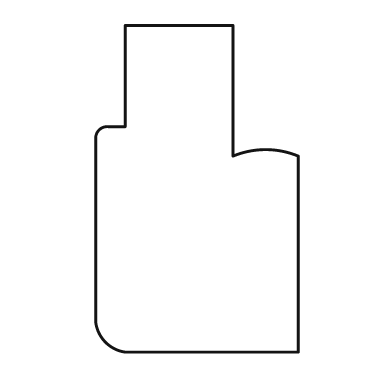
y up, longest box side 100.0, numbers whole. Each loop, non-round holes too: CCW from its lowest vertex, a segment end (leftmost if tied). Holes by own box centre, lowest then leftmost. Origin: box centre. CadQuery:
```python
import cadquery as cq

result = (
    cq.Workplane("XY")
    .moveTo(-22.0, -50.0)
    .lineTo(31.0, -50.0)
    .lineTo(31.0, 10.0)
    .threePointArc((21.0, 12.0), (11.0, 10.0))
    .lineTo(11.0, 50.0)
    .lineTo(-22.0, 50.0)
    .lineTo(-22.0, 19.0)
    .lineTo(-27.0, 19.0)
    .threePointArc((-30.0, 18.0), (-31.0, 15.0))
    .lineTo(-31.0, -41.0)
    .threePointArc((-28.0, -47.0), (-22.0, -50.0))
    .close()
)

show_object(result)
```